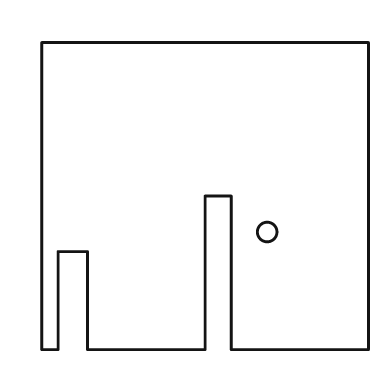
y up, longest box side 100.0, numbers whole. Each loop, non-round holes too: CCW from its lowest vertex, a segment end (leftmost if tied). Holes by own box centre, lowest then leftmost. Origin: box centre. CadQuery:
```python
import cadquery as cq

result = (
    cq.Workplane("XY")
    .moveTo(-50.0, -47.0)
    .lineTo(-45.0, -47.0)
    .lineTo(-45.0, -17.0)
    .lineTo(-36.0, -17.0)
    .lineTo(-36.0, -47.0)
    .lineTo(0.0, -47.0)
    .lineTo(0.0, 0.0)
    .lineTo(8.0, 0.0)
    .lineTo(8.0, -47.0)
    .lineTo(50.0, -47.0)
    .lineTo(50.0, 47.0)
    .lineTo(-50.0, 47.0)
    .close()
    .moveTo(19.0, -11.0)
    .circle(3.0)
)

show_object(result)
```